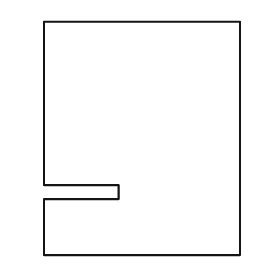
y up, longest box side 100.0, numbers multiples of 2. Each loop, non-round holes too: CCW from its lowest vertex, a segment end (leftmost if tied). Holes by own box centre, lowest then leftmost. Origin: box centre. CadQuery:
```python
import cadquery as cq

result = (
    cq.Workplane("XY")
    .moveTo(-42.0, -50.0)
    .lineTo(42.0, -50.0)
    .lineTo(42.0, 50.0)
    .lineTo(-42.0, 50.0)
    .lineTo(-42.0, -20.0)
    .lineTo(-10.0, -20.0)
    .lineTo(-10.0, -26.0)
    .lineTo(-42.0, -26.0)
    .close()
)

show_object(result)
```